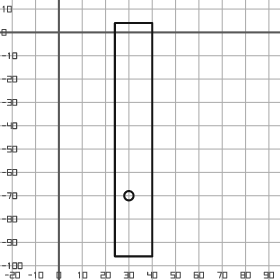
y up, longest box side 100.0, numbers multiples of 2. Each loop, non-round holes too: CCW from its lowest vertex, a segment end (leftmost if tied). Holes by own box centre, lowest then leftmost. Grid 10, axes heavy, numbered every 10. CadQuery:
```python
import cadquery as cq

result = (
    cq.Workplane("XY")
    .moveTo(24.0, -96.0)
    .lineTo(40.0, -96.0)
    .lineTo(40.0, 4.0)
    .lineTo(24.0, 4.0)
    .close()
    .moveTo(30.0, -70.0)
    .circle(2.0)
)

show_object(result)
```